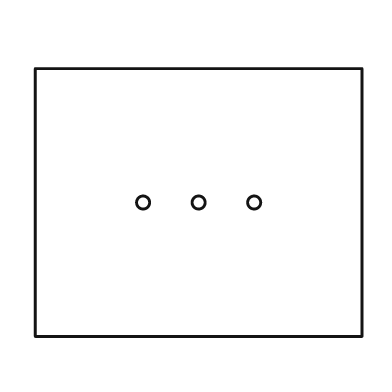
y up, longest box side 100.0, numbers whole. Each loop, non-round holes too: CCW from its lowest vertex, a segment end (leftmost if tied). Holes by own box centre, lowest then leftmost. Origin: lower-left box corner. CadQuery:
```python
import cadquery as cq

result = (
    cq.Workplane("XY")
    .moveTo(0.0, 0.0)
    .lineTo(100.0, 0.0)
    .lineTo(100.0, 82.0)
    .lineTo(0.0, 82.0)
    .close()
    .moveTo(33.0, 41.0)
    .circle(2.0)
    .moveTo(50.0, 41.0)
    .circle(2.0)
    .moveTo(67.0, 41.0)
    .circle(2.0)
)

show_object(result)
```